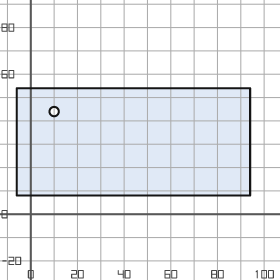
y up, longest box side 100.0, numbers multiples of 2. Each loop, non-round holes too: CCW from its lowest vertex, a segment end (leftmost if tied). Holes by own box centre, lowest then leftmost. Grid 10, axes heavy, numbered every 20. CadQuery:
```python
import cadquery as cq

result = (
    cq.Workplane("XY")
    .moveTo(-6.0, 8.0)
    .lineTo(94.0, 8.0)
    .lineTo(94.0, 54.0)
    .lineTo(-6.0, 54.0)
    .close()
    .moveTo(10.0, 44.0)
    .circle(2.0)
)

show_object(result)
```